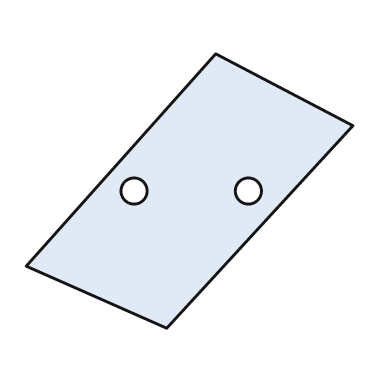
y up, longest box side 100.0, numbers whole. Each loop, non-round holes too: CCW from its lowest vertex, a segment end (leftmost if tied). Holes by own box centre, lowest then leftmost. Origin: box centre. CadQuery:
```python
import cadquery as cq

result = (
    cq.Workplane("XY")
    .moveTo(-7.0, -42.0)
    .lineTo(50.0, 20.0)
    .lineTo(8.0, 42.0)
    .lineTo(-50.0, -23.0)
    .close()
    .moveTo(-17.0, 0.0)
    .circle(4.0)
    .moveTo(18.0, 0.0)
    .circle(4.0)
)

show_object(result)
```